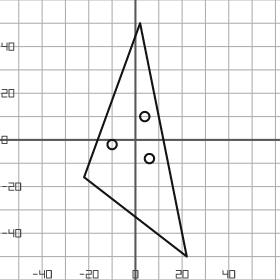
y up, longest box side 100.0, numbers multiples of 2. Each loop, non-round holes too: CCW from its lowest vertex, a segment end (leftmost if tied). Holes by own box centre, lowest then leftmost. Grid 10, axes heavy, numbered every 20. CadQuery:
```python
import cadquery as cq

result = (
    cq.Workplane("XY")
    .moveTo(22.0, -50.0)
    .lineTo(2.0, 50.0)
    .lineTo(-22.0, -16.0)
    .close()
    .moveTo(6.0, -8.0)
    .circle(2.0)
    .moveTo(-10.0, -2.0)
    .circle(2.0)
    .moveTo(4.0, 10.0)
    .circle(2.0)
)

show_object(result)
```